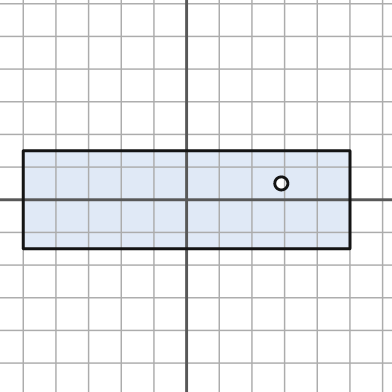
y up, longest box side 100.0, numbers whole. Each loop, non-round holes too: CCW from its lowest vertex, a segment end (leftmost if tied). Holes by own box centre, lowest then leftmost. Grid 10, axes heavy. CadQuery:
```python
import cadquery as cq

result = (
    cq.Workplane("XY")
    .moveTo(-50.0, -15.0)
    .lineTo(50.0, -15.0)
    .lineTo(50.0, 15.0)
    .lineTo(-50.0, 15.0)
    .close()
    .moveTo(29.0, 5.0)
    .circle(2.0)
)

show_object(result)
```